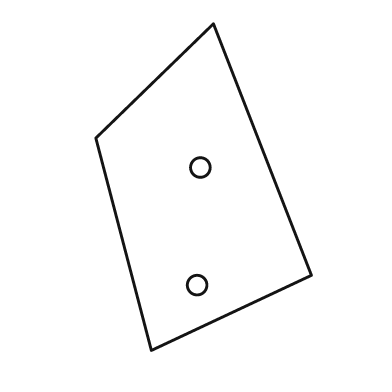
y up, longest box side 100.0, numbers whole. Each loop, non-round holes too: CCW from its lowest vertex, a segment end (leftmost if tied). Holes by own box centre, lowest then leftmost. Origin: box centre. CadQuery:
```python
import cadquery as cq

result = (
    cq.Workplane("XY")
    .moveTo(-16.0, -50.0)
    .lineTo(33.0, -27.0)
    .lineTo(3.0, 50.0)
    .lineTo(-33.0, 15.0)
    .close()
    .moveTo(-2.0, -30.0)
    .circle(3.0)
    .moveTo(-1.0, 6.0)
    .circle(3.0)
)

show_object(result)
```